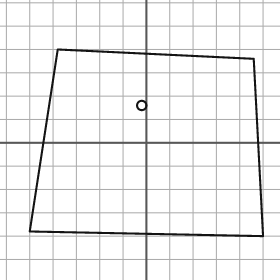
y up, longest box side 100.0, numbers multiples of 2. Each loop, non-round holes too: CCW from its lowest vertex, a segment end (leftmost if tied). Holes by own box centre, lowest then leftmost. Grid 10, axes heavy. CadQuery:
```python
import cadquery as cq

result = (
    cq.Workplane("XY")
    .moveTo(50.0, -40.0)
    .lineTo(46.0, 36.0)
    .lineTo(-38.0, 40.0)
    .lineTo(-50.0, -38.0)
    .close()
    .moveTo(-2.0, 16.0)
    .circle(2.0)
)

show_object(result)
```